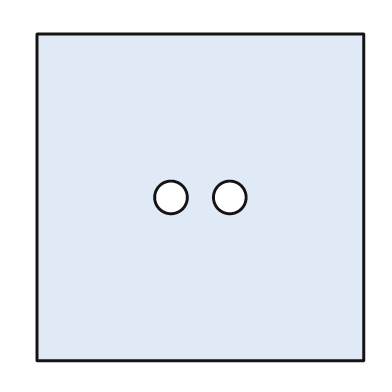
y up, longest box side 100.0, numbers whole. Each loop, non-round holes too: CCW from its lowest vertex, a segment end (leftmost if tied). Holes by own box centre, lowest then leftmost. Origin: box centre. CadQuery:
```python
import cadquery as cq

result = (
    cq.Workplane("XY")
    .moveTo(-50.0, -50.0)
    .lineTo(50.0, -50.0)
    .lineTo(50.0, 50.0)
    .lineTo(-50.0, 50.0)
    .close()
    .moveTo(-9.0, 0.0)
    .circle(5.0)
    .moveTo(9.0, 0.0)
    .circle(5.0)
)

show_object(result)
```